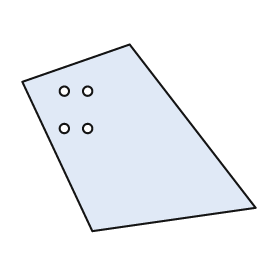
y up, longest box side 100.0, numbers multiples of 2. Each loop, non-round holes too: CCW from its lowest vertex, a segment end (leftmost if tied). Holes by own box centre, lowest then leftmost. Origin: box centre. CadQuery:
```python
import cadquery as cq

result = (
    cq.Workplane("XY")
    .moveTo(-20.0, -40.0)
    .lineTo(50.0, -30.0)
    .lineTo(-4.0, 40.0)
    .lineTo(-50.0, 24.0)
    .close()
    .moveTo(-32.0, 4.0)
    .circle(2.0)
    .moveTo(-22.0, 4.0)
    .circle(2.0)
    .moveTo(-32.0, 20.0)
    .circle(2.0)
    .moveTo(-22.0, 20.0)
    .circle(2.0)
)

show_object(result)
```